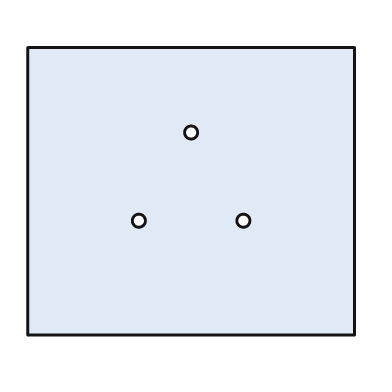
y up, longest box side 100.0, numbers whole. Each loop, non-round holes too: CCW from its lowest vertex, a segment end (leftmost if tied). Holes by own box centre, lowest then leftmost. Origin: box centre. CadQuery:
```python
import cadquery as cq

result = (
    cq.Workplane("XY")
    .moveTo(-50.0, -44.0)
    .lineTo(50.0, -44.0)
    .lineTo(50.0, 44.0)
    .lineTo(-50.0, 44.0)
    .close()
    .moveTo(-16.0, -9.0)
    .circle(2.0)
    .moveTo(16.0, -9.0)
    .circle(2.0)
    .moveTo(0.0, 18.0)
    .circle(2.0)
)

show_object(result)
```